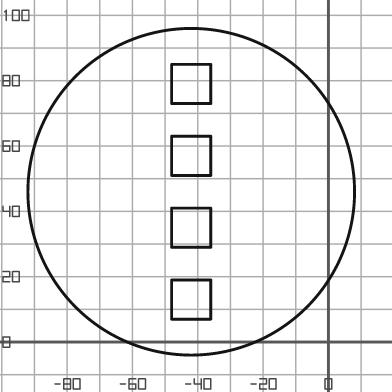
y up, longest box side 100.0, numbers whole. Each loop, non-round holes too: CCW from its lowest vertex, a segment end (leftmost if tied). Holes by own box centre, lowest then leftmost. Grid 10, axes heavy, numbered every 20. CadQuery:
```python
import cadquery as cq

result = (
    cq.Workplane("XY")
    .moveTo(-42.0, 46.0)
    .circle(50.0)
    .moveTo(-48.0, 7.0)
    .lineTo(-36.0, 7.0)
    .lineTo(-36.0, 19.0)
    .lineTo(-48.0, 19.0)
    .close()
    .moveTo(-48.0, 29.0)
    .lineTo(-36.0, 29.0)
    .lineTo(-36.0, 41.0)
    .lineTo(-48.0, 41.0)
    .close()
    .moveTo(-48.0, 51.0)
    .lineTo(-36.0, 51.0)
    .lineTo(-36.0, 63.0)
    .lineTo(-48.0, 63.0)
    .close()
    .moveTo(-48.0, 73.0)
    .lineTo(-36.0, 73.0)
    .lineTo(-36.0, 85.0)
    .lineTo(-48.0, 85.0)
    .close()
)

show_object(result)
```